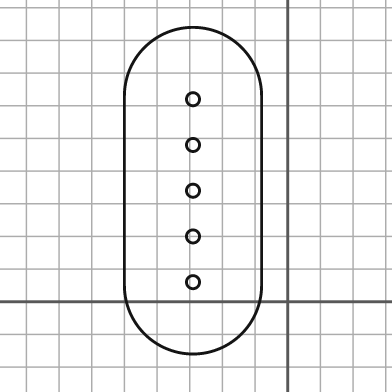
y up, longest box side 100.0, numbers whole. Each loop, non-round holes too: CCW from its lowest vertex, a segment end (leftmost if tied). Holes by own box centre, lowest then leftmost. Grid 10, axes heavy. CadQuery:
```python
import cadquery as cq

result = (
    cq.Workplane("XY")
    .moveTo(-50.0, 5.0)
    .threePointArc((-29.0, -16.0), (-8.0, 5.0))
    .lineTo(-8.0, 63.0)
    .threePointArc((-29.0, 84.0), (-50.0, 63.0))
    .close()
    .moveTo(-29.0, 6.0)
    .circle(2.0)
    .moveTo(-29.0, 20.0)
    .circle(2.0)
    .moveTo(-29.0, 34.0)
    .circle(2.0)
    .moveTo(-29.0, 48.0)
    .circle(2.0)
    .moveTo(-29.0, 62.0)
    .circle(2.0)
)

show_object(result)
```